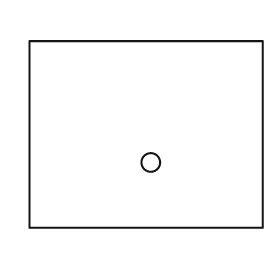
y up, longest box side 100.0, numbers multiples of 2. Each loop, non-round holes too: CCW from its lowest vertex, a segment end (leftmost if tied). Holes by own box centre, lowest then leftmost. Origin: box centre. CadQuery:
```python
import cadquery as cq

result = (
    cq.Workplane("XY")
    .moveTo(-50.0, -40.0)
    .lineTo(50.0, -40.0)
    .lineTo(50.0, 40.0)
    .lineTo(-50.0, 40.0)
    .close()
    .moveTo(2.0, -12.0)
    .circle(4.0)
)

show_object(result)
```